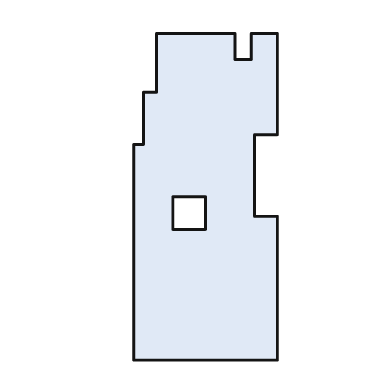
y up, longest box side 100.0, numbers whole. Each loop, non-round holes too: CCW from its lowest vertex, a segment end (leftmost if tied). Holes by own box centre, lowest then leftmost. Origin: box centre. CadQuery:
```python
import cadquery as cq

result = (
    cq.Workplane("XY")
    .moveTo(-22.0, -50.0)
    .lineTo(22.0, -50.0)
    .lineTo(22.0, -6.0)
    .lineTo(15.0, -6.0)
    .lineTo(15.0, 19.0)
    .lineTo(22.0, 19.0)
    .lineTo(22.0, 50.0)
    .lineTo(14.0, 50.0)
    .lineTo(14.0, 42.0)
    .lineTo(9.0, 42.0)
    .lineTo(9.0, 50.0)
    .lineTo(-15.0, 50.0)
    .lineTo(-15.0, 32.0)
    .lineTo(-19.0, 32.0)
    .lineTo(-19.0, 16.0)
    .lineTo(-22.0, 16.0)
    .close()
    .moveTo(-10.0, -10.0)
    .lineTo(0.0, -10.0)
    .lineTo(0.0, 0.0)
    .lineTo(-10.0, 0.0)
    .close()
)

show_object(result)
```